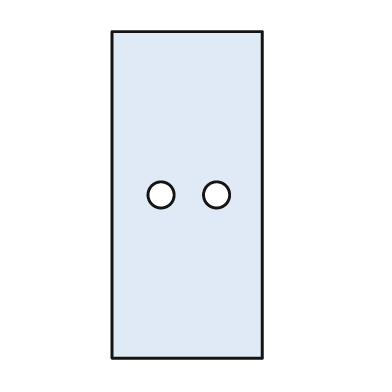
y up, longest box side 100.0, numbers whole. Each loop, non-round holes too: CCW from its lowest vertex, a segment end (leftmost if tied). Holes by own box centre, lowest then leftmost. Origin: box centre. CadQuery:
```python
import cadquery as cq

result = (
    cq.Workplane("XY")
    .moveTo(-23.0, -50.0)
    .lineTo(23.0, -50.0)
    .lineTo(23.0, 50.0)
    .lineTo(-23.0, 50.0)
    .close()
    .moveTo(-8.0, 0.0)
    .circle(4.0)
    .moveTo(9.0, 0.0)
    .circle(4.0)
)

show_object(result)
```